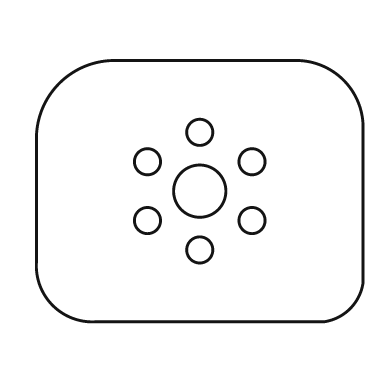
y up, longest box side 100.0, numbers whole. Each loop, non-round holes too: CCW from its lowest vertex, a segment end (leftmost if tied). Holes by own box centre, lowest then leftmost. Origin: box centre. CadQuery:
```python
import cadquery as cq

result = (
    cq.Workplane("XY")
    .moveTo(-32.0, -40.0)
    .lineTo(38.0, -40.0)
    .threePointArc((46.0, -36.0), (50.0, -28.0))
    .lineTo(50.0, 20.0)
    .threePointArc((44.0, 34.0), (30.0, 40.0))
    .lineTo(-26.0, 40.0)
    .threePointArc((-43.0, 33.0), (-50.0, 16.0))
    .lineTo(-50.0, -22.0)
    .threePointArc((-45.0, -35.0), (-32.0, -40.0))
    .close()
    .moveTo(0.0, -18.0)
    .circle(4.0)
    .moveTo(-16.0, -9.0)
    .circle(4.0)
    .moveTo(16.0, -9.0)
    .circle(4.0)
    .moveTo(0.0, 0.0)
    .circle(8.0)
    .moveTo(-16.0, 9.0)
    .circle(4.0)
    .moveTo(16.0, 9.0)
    .circle(4.0)
    .moveTo(0.0, 18.0)
    .circle(4.0)
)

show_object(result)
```